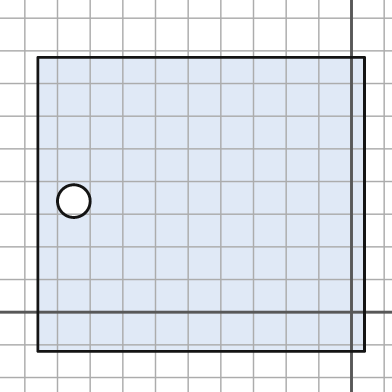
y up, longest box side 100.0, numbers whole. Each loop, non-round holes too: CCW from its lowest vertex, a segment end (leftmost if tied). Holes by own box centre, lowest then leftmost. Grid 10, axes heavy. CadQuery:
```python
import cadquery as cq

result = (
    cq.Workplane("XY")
    .moveTo(-96.0, -12.0)
    .lineTo(4.0, -12.0)
    .lineTo(4.0, 78.0)
    .lineTo(-96.0, 78.0)
    .close()
    .moveTo(-85.0, 34.0)
    .circle(5.0)
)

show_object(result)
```